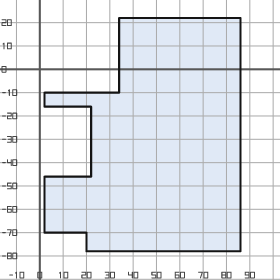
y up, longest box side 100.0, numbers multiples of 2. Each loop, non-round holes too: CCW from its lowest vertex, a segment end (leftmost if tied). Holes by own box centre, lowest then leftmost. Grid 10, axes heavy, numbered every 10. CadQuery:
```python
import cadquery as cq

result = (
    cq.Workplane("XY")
    .moveTo(20.0, -78.0)
    .lineTo(86.0, -78.0)
    .lineTo(86.0, 22.0)
    .lineTo(34.0, 22.0)
    .lineTo(34.0, -10.0)
    .lineTo(2.0, -10.0)
    .lineTo(2.0, -16.0)
    .lineTo(22.0, -16.0)
    .lineTo(22.0, -46.0)
    .lineTo(2.0, -46.0)
    .lineTo(2.0, -70.0)
    .lineTo(20.0, -70.0)
    .close()
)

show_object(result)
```